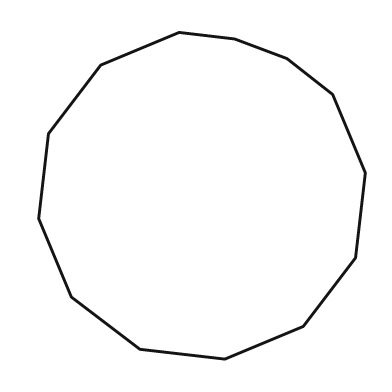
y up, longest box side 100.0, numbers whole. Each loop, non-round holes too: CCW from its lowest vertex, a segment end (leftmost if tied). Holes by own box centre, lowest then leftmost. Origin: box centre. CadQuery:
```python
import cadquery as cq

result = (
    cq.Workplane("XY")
    .moveTo(7.0, -50.0)
    .lineTo(31.0, -40.0)
    .lineTo(47.0, -19.0)
    .lineTo(50.0, 7.0)
    .lineTo(40.0, 31.0)
    .lineTo(26.0, 42.0)
    .lineTo(10.0, 48.0)
    .lineTo(-7.0, 50.0)
    .lineTo(-31.0, 40.0)
    .lineTo(-47.0, 19.0)
    .lineTo(-50.0, -7.0)
    .lineTo(-40.0, -31.0)
    .lineTo(-19.0, -47.0)
    .close()
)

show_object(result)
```